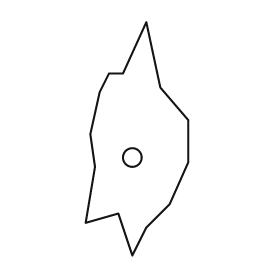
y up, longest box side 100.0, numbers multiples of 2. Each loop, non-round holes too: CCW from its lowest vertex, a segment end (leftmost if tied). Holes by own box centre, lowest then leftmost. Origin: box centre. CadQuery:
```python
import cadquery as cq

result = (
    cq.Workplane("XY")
    .moveTo(-2.0, -50.0)
    .lineTo(4.0, -38.0)
    .lineTo(14.0, -28.0)
    .lineTo(22.0, -10.0)
    .lineTo(22.0, 8.0)
    .lineTo(10.0, 22.0)
    .lineTo(4.0, 50.0)
    .lineTo(-6.0, 28.0)
    .lineTo(-12.0, 28.0)
    .lineTo(-16.0, 20.0)
    .lineTo(-20.0, 2.0)
    .lineTo(-18.0, -12.0)
    .lineTo(-22.0, -36.0)
    .lineTo(-8.0, -32.0)
    .close()
    .moveTo(-2.0, -8.0)
    .circle(4.0)
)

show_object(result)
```